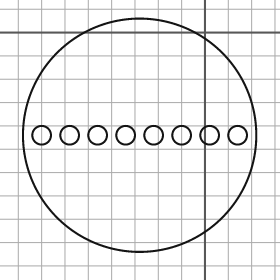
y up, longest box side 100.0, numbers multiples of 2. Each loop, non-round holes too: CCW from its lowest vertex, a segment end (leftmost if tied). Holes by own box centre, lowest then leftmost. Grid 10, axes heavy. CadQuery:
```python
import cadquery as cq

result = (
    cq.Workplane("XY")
    .moveTo(-28.0, -44.0)
    .circle(50.0)
    .moveTo(-70.0, -44.0)
    .circle(4.0)
    .moveTo(-58.0, -44.0)
    .circle(4.0)
    .moveTo(-46.0, -44.0)
    .circle(4.0)
    .moveTo(-34.0, -44.0)
    .circle(4.0)
    .moveTo(-22.0, -44.0)
    .circle(4.0)
    .moveTo(-10.0, -44.0)
    .circle(4.0)
    .moveTo(2.0, -44.0)
    .circle(4.0)
    .moveTo(14.0, -44.0)
    .circle(4.0)
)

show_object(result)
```